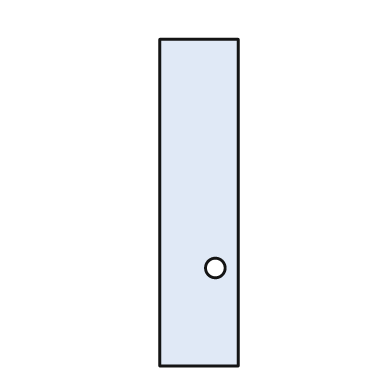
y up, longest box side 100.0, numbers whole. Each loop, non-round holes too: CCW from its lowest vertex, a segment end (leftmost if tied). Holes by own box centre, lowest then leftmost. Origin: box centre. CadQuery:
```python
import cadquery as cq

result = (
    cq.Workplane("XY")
    .moveTo(-12.0, -50.0)
    .lineTo(12.0, -50.0)
    .lineTo(12.0, 50.0)
    .lineTo(-12.0, 50.0)
    .close()
    .moveTo(5.0, -20.0)
    .circle(3.0)
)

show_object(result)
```